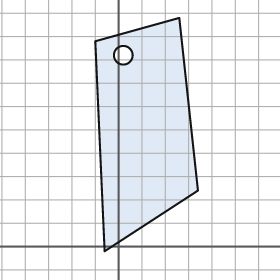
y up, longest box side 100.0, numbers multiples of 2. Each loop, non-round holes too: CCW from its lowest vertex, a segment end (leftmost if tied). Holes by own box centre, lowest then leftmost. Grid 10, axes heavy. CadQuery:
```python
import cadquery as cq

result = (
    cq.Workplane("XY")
    .moveTo(-6.0, -2.0)
    .lineTo(34.0, 24.0)
    .lineTo(26.0, 98.0)
    .lineTo(-10.0, 88.0)
    .close()
    .moveTo(2.0, 82.0)
    .circle(4.0)
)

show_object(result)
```